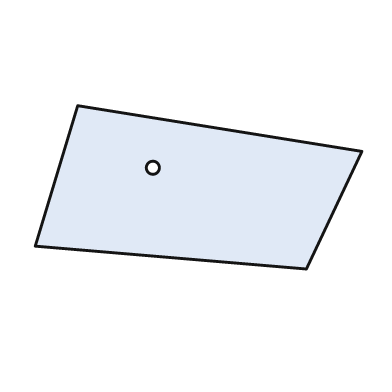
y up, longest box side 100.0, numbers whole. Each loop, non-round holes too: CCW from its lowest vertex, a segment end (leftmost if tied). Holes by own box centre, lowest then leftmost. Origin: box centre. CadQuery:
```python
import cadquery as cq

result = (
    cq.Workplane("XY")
    .moveTo(33.0, -25.0)
    .lineTo(50.0, 11.0)
    .lineTo(-37.0, 25.0)
    .lineTo(-50.0, -18.0)
    .close()
    .moveTo(-14.0, 6.0)
    .circle(2.0)
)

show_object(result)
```